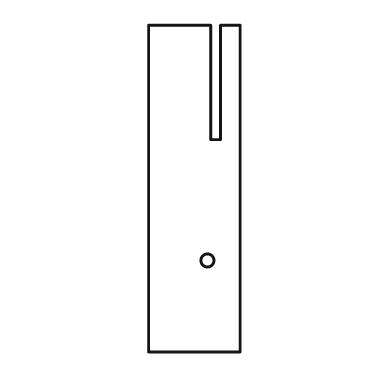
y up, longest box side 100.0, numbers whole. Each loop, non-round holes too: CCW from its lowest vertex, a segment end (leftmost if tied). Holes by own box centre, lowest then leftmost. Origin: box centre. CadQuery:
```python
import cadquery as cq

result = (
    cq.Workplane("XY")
    .moveTo(-14.0, -50.0)
    .lineTo(14.0, -50.0)
    .lineTo(14.0, 50.0)
    .lineTo(8.0, 50.0)
    .lineTo(8.0, 15.0)
    .lineTo(5.0, 15.0)
    .lineTo(5.0, 50.0)
    .lineTo(-14.0, 50.0)
    .close()
    .moveTo(4.0, -22.0)
    .circle(2.0)
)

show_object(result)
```